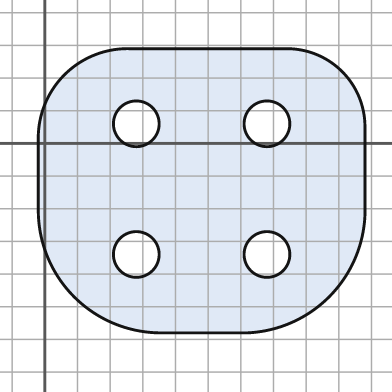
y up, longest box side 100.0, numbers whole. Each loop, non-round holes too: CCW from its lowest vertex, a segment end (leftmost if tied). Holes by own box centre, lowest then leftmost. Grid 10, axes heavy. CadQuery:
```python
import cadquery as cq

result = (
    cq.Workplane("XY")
    .moveTo(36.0, -58.0)
    .lineTo(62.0, -58.0)
    .threePointArc((87.0, -47.0), (98.0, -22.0))
    .lineTo(98.0, 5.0)
    .threePointArc((91.0, 22.0), (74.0, 29.0))
    .lineTo(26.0, 29.0)
    .threePointArc((6.0, 21.0), (-2.0, 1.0))
    .lineTo(-2.0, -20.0)
    .threePointArc((9.0, -47.0), (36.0, -58.0))
    .close()
    .moveTo(28.0, -34.0)
    .circle(7.0)
    .moveTo(68.0, -34.0)
    .circle(7.0)
    .moveTo(28.0, 6.0)
    .circle(7.0)
    .moveTo(68.0, 6.0)
    .circle(7.0)
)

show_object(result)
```